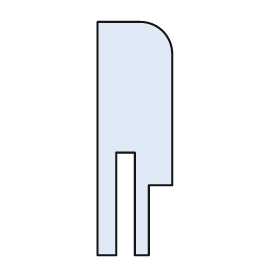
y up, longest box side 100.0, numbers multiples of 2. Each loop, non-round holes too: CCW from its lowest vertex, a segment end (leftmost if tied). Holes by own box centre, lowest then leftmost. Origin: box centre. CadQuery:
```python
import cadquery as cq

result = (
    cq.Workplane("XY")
    .moveTo(-16.0, -50.0)
    .lineTo(-8.0, -50.0)
    .lineTo(-8.0, -6.0)
    .lineTo(0.0, -6.0)
    .lineTo(0.0, -50.0)
    .lineTo(6.0, -50.0)
    .lineTo(6.0, -20.0)
    .lineTo(16.0, -20.0)
    .lineTo(16.0, 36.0)
    .threePointArc((12.0, 46.0), (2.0, 50.0))
    .lineTo(-16.0, 50.0)
    .close()
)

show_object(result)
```